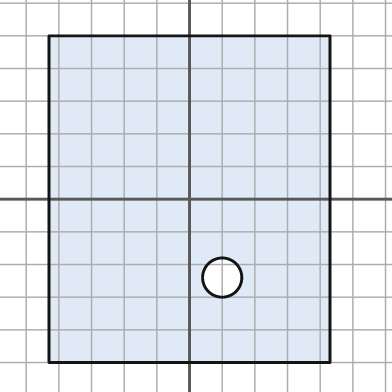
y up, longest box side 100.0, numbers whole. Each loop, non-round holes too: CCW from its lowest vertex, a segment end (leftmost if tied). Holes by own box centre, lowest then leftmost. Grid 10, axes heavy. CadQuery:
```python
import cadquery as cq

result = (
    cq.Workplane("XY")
    .moveTo(-43.0, -50.0)
    .lineTo(43.0, -50.0)
    .lineTo(43.0, 50.0)
    .lineTo(-43.0, 50.0)
    .close()
    .moveTo(10.0, -24.0)
    .circle(6.0)
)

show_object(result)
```